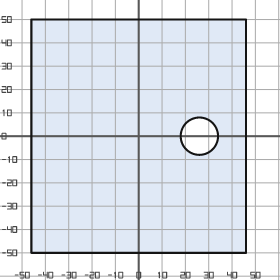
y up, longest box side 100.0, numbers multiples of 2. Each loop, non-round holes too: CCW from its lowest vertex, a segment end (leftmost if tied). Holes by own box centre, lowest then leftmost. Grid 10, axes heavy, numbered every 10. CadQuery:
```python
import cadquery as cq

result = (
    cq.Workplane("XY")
    .moveTo(-46.0, -50.0)
    .lineTo(46.0, -50.0)
    .lineTo(46.0, 50.0)
    .lineTo(-46.0, 50.0)
    .close()
    .moveTo(26.0, 0.0)
    .circle(8.0)
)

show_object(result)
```